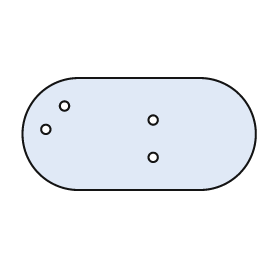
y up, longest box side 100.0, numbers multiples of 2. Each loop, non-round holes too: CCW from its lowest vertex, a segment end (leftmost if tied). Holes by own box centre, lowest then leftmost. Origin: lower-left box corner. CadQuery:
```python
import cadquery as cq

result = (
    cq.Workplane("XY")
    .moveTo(24.0, 0.0)
    .lineTo(76.0, 0.0)
    .threePointArc((100.0, 24.0), (76.0, 48.0))
    .lineTo(24.0, 48.0)
    .threePointArc((0.0, 24.0), (24.0, 0.0))
    .close()
    .moveTo(56.0, 14.0)
    .circle(2.0)
    .moveTo(10.0, 26.0)
    .circle(2.0)
    .moveTo(56.0, 30.0)
    .circle(2.0)
    .moveTo(18.0, 36.0)
    .circle(2.0)
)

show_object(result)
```